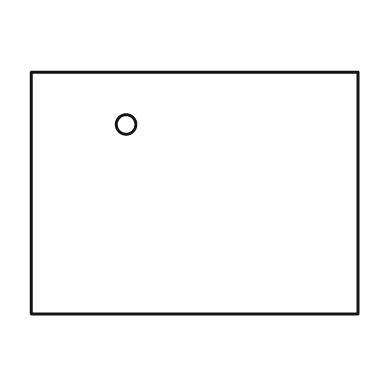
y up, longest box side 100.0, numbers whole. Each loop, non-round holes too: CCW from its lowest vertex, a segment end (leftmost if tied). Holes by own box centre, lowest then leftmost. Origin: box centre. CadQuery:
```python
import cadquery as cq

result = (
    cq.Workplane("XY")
    .moveTo(-50.0, -37.0)
    .lineTo(50.0, -37.0)
    .lineTo(50.0, 37.0)
    .lineTo(-50.0, 37.0)
    .close()
    .moveTo(-21.0, 21.0)
    .circle(3.0)
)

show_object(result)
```